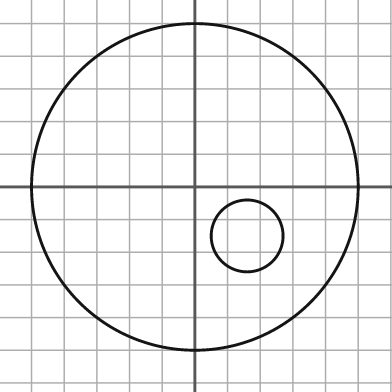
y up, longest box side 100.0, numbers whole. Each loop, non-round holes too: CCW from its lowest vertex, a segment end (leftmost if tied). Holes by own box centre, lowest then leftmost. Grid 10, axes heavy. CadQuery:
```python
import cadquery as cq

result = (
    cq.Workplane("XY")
    .moveTo(0.0, 0.0)
    .circle(50.0)
    .moveTo(16.0, -15.0)
    .circle(11.0)
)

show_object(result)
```